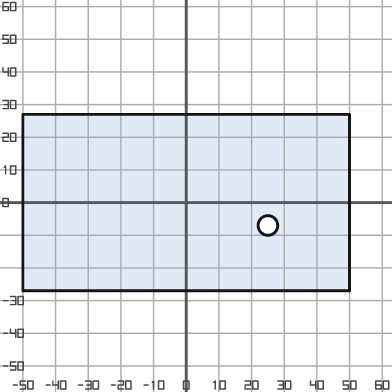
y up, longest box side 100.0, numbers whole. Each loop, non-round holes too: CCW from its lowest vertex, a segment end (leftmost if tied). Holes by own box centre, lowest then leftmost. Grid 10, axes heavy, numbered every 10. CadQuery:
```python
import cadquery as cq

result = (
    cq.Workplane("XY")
    .moveTo(-50.0, -27.0)
    .lineTo(50.0, -27.0)
    .lineTo(50.0, 27.0)
    .lineTo(-50.0, 27.0)
    .close()
    .moveTo(25.0, -7.0)
    .circle(3.0)
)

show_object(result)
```